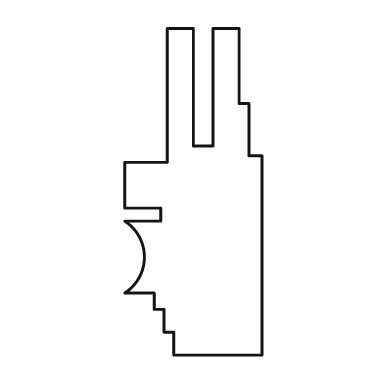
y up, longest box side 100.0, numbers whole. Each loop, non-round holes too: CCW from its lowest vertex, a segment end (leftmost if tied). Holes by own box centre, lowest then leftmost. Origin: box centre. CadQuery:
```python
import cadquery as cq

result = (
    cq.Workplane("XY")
    .moveTo(-6.0, -50.0)
    .lineTo(21.0, -50.0)
    .lineTo(21.0, 11.0)
    .lineTo(17.0, 11.0)
    .lineTo(17.0, 27.0)
    .lineTo(14.0, 27.0)
    .lineTo(14.0, 50.0)
    .lineTo(6.0, 50.0)
    .lineTo(6.0, 14.0)
    .lineTo(0.0, 14.0)
    .lineTo(0.0, 50.0)
    .lineTo(-8.0, 50.0)
    .lineTo(-8.0, 9.0)
    .lineTo(-21.0, 9.0)
    .lineTo(-21.0, -5.0)
    .lineTo(-10.0, -5.0)
    .lineTo(-10.0, -9.0)
    .lineTo(-21.0, -9.0)
    .threePointArc((-15.0, -20.0), (-21.0, -31.0))
    .lineTo(-12.0, -31.0)
    .lineTo(-12.0, -36.0)
    .lineTo(-9.0, -36.0)
    .lineTo(-9.0, -43.0)
    .lineTo(-6.0, -43.0)
    .close()
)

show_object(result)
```